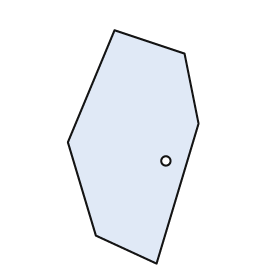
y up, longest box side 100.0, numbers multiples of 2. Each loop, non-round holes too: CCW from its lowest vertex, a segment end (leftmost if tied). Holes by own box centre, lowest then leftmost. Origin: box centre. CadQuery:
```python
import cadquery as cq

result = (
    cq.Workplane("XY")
    .moveTo(10.0, -50.0)
    .lineTo(28.0, 10.0)
    .lineTo(22.0, 40.0)
    .lineTo(-8.0, 50.0)
    .lineTo(-28.0, 2.0)
    .lineTo(-16.0, -38.0)
    .close()
    .moveTo(14.0, -6.0)
    .circle(2.0)
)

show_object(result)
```